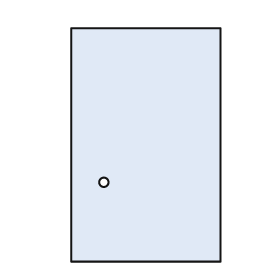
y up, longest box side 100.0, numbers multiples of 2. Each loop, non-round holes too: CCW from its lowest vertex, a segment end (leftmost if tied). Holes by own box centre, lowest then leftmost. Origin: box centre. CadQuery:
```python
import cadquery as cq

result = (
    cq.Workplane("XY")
    .moveTo(-32.0, -50.0)
    .lineTo(32.0, -50.0)
    .lineTo(32.0, 50.0)
    .lineTo(-32.0, 50.0)
    .close()
    .moveTo(-18.0, -16.0)
    .circle(2.0)
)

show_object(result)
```